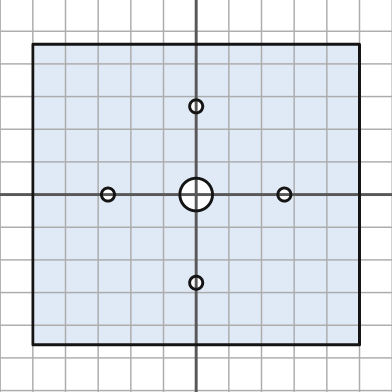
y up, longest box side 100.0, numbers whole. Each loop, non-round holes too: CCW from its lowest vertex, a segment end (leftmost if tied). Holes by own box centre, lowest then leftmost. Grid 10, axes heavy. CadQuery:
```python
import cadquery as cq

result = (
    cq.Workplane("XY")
    .moveTo(-50.0, -46.0)
    .lineTo(50.0, -46.0)
    .lineTo(50.0, 46.0)
    .lineTo(-50.0, 46.0)
    .close()
    .moveTo(0.0, -27.0)
    .circle(2.0)
    .moveTo(-27.0, 0.0)
    .circle(2.0)
    .moveTo(0.0, 0.0)
    .circle(5.0)
    .moveTo(27.0, 0.0)
    .circle(2.0)
    .moveTo(0.0, 27.0)
    .circle(2.0)
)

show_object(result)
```